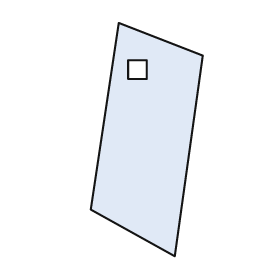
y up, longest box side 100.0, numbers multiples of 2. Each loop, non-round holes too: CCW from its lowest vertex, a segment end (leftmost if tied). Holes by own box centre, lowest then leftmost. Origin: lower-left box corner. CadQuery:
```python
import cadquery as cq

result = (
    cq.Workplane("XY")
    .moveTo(36.0, 0.0)
    .lineTo(48.0, 86.0)
    .lineTo(12.0, 100.0)
    .lineTo(0.0, 20.0)
    .close()
    .moveTo(16.0, 76.0)
    .lineTo(24.0, 76.0)
    .lineTo(24.0, 84.0)
    .lineTo(16.0, 84.0)
    .close()
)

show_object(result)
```